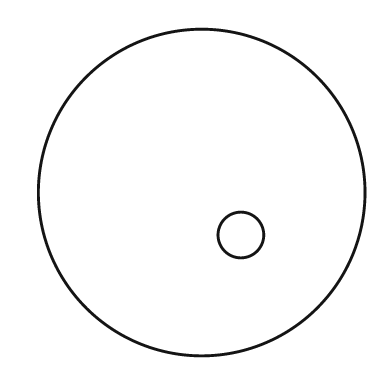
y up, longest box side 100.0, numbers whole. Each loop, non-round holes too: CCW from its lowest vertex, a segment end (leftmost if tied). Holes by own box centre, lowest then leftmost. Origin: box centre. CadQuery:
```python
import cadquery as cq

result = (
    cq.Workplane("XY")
    .moveTo(0.0, 0.0)
    .circle(50.0)
    .moveTo(12.0, -13.0)
    .circle(7.0)
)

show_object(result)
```